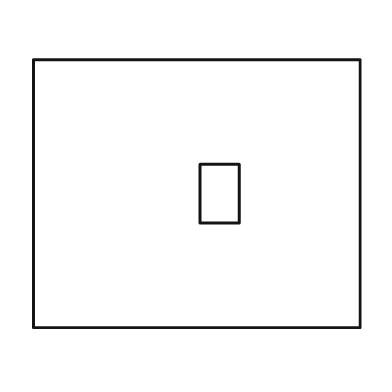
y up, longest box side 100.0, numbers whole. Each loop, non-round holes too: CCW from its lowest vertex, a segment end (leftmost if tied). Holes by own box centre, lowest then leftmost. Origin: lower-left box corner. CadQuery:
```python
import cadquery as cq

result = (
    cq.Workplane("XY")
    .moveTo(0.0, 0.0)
    .lineTo(100.0, 0.0)
    .lineTo(100.0, 82.0)
    .lineTo(0.0, 82.0)
    .close()
    .moveTo(51.0, 32.0)
    .lineTo(63.0, 32.0)
    .lineTo(63.0, 50.0)
    .lineTo(51.0, 50.0)
    .close()
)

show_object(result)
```